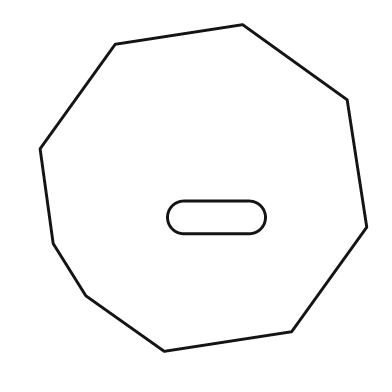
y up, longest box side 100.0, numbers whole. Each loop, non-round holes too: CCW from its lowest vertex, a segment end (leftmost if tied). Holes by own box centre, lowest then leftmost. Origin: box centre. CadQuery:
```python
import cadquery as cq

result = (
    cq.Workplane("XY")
    .moveTo(-12.0, -50.0)
    .lineTo(27.0, -44.0)
    .lineTo(50.0, -12.0)
    .lineTo(44.0, 27.0)
    .lineTo(12.0, 50.0)
    .lineTo(-27.0, 44.0)
    .lineTo(-50.0, 12.0)
    .lineTo(-46.0, -17.0)
    .lineTo(-36.0, -33.0)
    .close()
    .moveTo(-6.0, -14.0)
    .lineTo(14.0, -14.0)
    .threePointArc((19.0, -9.0), (14.0, -4.0))
    .lineTo(-6.0, -4.0)
    .threePointArc((-11.0, -9.0), (-6.0, -14.0))
    .close()
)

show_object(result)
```